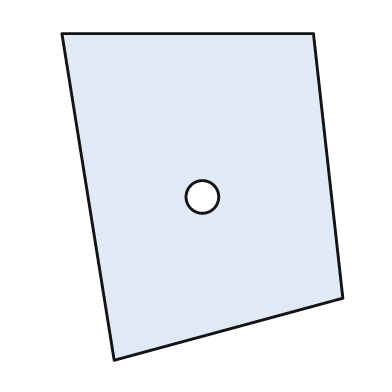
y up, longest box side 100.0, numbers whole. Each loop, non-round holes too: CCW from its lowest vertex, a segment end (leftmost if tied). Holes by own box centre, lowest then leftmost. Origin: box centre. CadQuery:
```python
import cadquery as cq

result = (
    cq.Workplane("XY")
    .moveTo(-27.0, -50.0)
    .lineTo(43.0, -31.0)
    .lineTo(34.0, 50.0)
    .lineTo(-43.0, 50.0)
    .close()
    .moveTo(0.0, 0.0)
    .circle(5.0)
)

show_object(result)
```